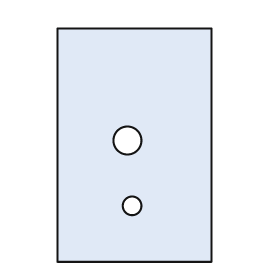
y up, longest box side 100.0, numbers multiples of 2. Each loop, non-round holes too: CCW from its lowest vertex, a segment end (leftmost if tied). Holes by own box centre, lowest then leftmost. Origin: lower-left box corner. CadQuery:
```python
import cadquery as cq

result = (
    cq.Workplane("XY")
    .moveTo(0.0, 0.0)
    .lineTo(66.0, 0.0)
    .lineTo(66.0, 100.0)
    .lineTo(0.0, 100.0)
    .close()
    .moveTo(32.0, 24.0)
    .circle(4.0)
    .moveTo(30.0, 52.0)
    .circle(6.0)
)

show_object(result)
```